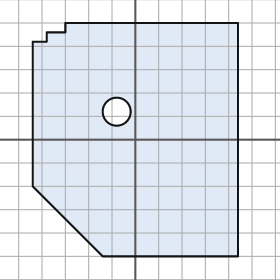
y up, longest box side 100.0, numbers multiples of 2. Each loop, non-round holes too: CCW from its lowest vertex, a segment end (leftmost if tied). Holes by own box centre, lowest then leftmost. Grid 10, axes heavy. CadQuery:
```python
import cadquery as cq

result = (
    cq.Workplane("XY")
    .moveTo(-14.0, -50.0)
    .lineTo(44.0, -50.0)
    .lineTo(44.0, 50.0)
    .lineTo(-30.0, 50.0)
    .lineTo(-30.0, 46.0)
    .lineTo(-38.0, 46.0)
    .lineTo(-38.0, 42.0)
    .lineTo(-44.0, 42.0)
    .lineTo(-44.0, -20.0)
    .close()
    .moveTo(-8.0, 12.0)
    .circle(6.0)
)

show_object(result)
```